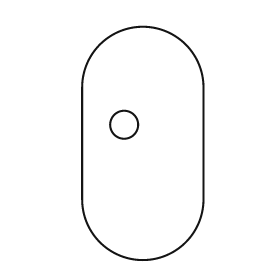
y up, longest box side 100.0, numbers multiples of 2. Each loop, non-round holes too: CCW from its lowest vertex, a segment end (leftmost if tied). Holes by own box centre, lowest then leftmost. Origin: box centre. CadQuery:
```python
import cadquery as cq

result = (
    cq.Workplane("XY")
    .moveTo(-26.0, -24.0)
    .threePointArc((0.0, -50.0), (26.0, -24.0))
    .lineTo(26.0, 24.0)
    .threePointArc((0.0, 50.0), (-26.0, 24.0))
    .close()
    .moveTo(-8.0, 8.0)
    .circle(6.0)
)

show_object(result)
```